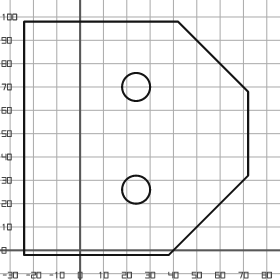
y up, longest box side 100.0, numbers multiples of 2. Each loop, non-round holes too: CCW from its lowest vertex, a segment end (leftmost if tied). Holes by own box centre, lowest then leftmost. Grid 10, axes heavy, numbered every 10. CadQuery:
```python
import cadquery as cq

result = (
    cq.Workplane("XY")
    .moveTo(-24.0, -2.0)
    .lineTo(38.0, -2.0)
    .lineTo(72.0, 32.0)
    .lineTo(72.0, 68.0)
    .lineTo(42.0, 98.0)
    .lineTo(-24.0, 98.0)
    .close()
    .moveTo(24.0, 26.0)
    .circle(6.0)
    .moveTo(24.0, 70.0)
    .circle(6.0)
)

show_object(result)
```